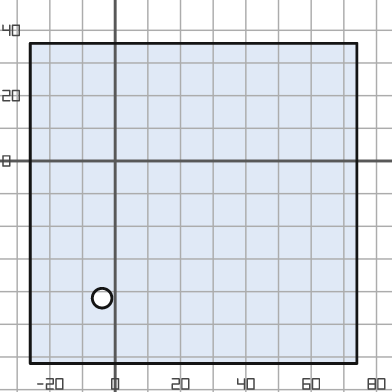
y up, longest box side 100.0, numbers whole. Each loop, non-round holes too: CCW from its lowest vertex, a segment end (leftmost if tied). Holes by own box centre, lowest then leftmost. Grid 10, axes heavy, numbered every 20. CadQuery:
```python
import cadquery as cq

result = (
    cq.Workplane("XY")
    .moveTo(-26.0, -62.0)
    .lineTo(74.0, -62.0)
    .lineTo(74.0, 36.0)
    .lineTo(-26.0, 36.0)
    .close()
    .moveTo(-4.0, -42.0)
    .circle(3.0)
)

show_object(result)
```